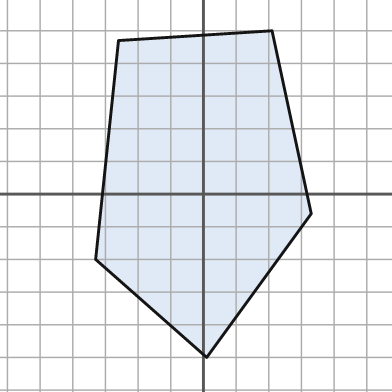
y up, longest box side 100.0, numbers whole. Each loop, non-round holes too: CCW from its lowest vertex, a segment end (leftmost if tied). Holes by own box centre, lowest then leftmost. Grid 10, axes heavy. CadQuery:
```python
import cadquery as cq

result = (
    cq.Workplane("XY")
    .moveTo(1.0, -50.0)
    .lineTo(33.0, -6.0)
    .lineTo(21.0, 50.0)
    .lineTo(-26.0, 47.0)
    .lineTo(-33.0, -20.0)
    .close()
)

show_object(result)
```